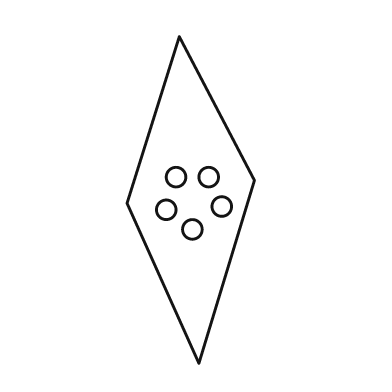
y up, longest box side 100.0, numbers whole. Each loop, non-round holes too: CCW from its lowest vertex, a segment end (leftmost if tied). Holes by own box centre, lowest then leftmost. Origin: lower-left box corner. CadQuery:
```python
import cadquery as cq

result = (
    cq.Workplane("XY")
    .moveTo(22.0, 0.0)
    .lineTo(39.0, 56.0)
    .lineTo(16.0, 100.0)
    .lineTo(0.0, 49.0)
    .close()
    .moveTo(20.0, 41.0)
    .circle(3.0)
    .moveTo(12.0, 47.0)
    .circle(3.0)
    .moveTo(29.0, 48.0)
    .circle(3.0)
    .moveTo(15.0, 57.0)
    .circle(3.0)
    .moveTo(25.0, 57.0)
    .circle(3.0)
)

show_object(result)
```